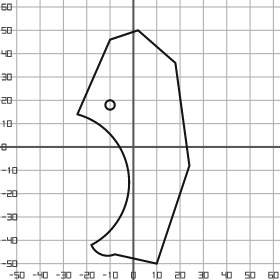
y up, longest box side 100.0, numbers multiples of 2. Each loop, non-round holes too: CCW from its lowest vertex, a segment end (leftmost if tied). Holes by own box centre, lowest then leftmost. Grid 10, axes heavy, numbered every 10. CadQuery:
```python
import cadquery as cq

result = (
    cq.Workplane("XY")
    .moveTo(10.0, -50.0)
    .lineTo(24.0, -8.0)
    .lineTo(18.0, 36.0)
    .lineTo(2.0, 50.0)
    .lineTo(-10.0, 46.0)
    .lineTo(-24.0, 14.0)
    .threePointArc((-2.0, -12.0), (-18.0, -42.0))
    .threePointArc((-14.0, -46.0), (-8.0, -46.0))
    .close()
    .moveTo(-10.0, 18.0)
    .circle(2.0)
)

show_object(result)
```